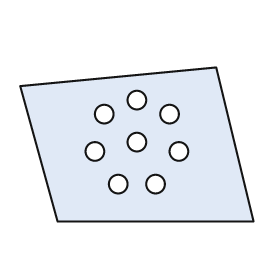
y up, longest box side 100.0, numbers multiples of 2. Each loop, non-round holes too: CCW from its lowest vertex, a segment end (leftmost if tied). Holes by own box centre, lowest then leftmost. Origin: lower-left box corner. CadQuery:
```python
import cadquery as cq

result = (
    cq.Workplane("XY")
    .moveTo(16.0, 0.0)
    .lineTo(100.0, 0.0)
    .lineTo(84.0, 66.0)
    .lineTo(0.0, 58.0)
    .close()
    .moveTo(42.0, 16.0)
    .circle(4.0)
    .moveTo(58.0, 16.0)
    .circle(4.0)
    .moveTo(32.0, 30.0)
    .circle(4.0)
    .moveTo(68.0, 30.0)
    .circle(4.0)
    .moveTo(50.0, 34.0)
    .circle(4.0)
    .moveTo(36.0, 46.0)
    .circle(4.0)
    .moveTo(64.0, 46.0)
    .circle(4.0)
    .moveTo(50.0, 52.0)
    .circle(4.0)
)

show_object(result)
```